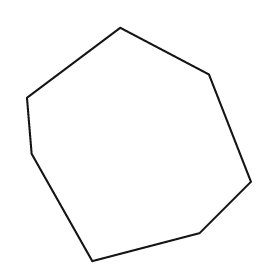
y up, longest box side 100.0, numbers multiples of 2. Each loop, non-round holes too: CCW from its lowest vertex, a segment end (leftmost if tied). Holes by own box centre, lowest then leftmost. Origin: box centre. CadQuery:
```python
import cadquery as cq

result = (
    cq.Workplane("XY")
    .moveTo(-20.0, -50.0)
    .lineTo(26.0, -38.0)
    .lineTo(48.0, -16.0)
    .lineTo(30.0, 30.0)
    .lineTo(-8.0, 50.0)
    .lineTo(-48.0, 20.0)
    .lineTo(-46.0, -4.0)
    .close()
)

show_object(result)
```